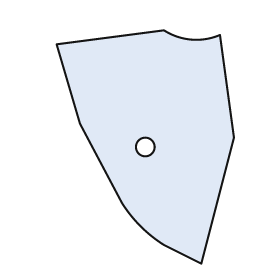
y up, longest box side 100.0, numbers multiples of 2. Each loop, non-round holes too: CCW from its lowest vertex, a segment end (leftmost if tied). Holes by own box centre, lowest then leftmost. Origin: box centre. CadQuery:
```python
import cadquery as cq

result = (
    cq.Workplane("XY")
    .moveTo(24.0, -50.0)
    .lineTo(38.0, 4.0)
    .lineTo(32.0, 48.0)
    .threePointArc((20.0, 46.0), (8.0, 50.0))
    .lineTo(-38.0, 44.0)
    .lineTo(-28.0, 10.0)
    .lineTo(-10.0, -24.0)
    .threePointArc((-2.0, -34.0), (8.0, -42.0))
    .close()
    .moveTo(0.0, 0.0)
    .circle(4.0)
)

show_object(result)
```